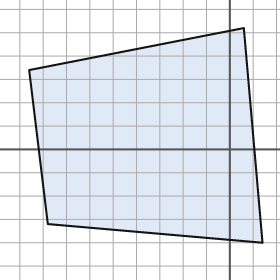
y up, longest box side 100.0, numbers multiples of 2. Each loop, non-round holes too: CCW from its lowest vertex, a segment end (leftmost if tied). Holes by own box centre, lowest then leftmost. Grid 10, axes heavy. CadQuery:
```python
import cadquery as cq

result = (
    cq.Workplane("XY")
    .moveTo(14.0, -40.0)
    .lineTo(6.0, 52.0)
    .lineTo(-86.0, 34.0)
    .lineTo(-78.0, -32.0)
    .close()
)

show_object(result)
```